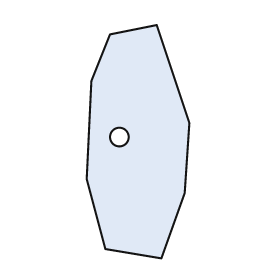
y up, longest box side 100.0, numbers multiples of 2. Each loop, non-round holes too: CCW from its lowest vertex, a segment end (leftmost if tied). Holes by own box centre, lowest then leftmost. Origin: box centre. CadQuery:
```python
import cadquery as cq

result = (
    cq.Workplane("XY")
    .moveTo(10.0, -50.0)
    .lineTo(20.0, -22.0)
    .lineTo(22.0, 8.0)
    .lineTo(8.0, 50.0)
    .lineTo(-12.0, 46.0)
    .lineTo(-20.0, 26.0)
    .lineTo(-22.0, -16.0)
    .lineTo(-14.0, -46.0)
    .close()
    .moveTo(-8.0, 2.0)
    .circle(4.0)
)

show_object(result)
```